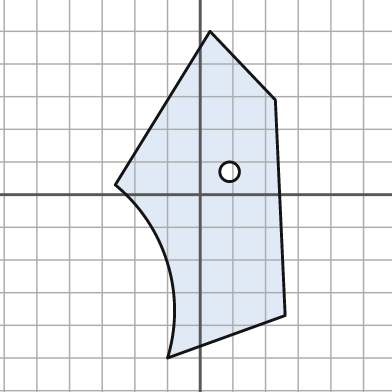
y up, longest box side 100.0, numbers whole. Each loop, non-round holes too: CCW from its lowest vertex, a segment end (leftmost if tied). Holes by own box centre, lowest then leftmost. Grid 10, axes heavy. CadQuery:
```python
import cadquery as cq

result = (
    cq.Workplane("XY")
    .moveTo(-10.0, -50.0)
    .lineTo(26.0, -37.0)
    .lineTo(23.0, 29.0)
    .lineTo(3.0, 50.0)
    .lineTo(-26.0, 3.0)
    .threePointArc((-10.0, -21.0), (-10.0, -50.0))
    .close()
    .moveTo(9.0, 7.0)
    .circle(3.0)
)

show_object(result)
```